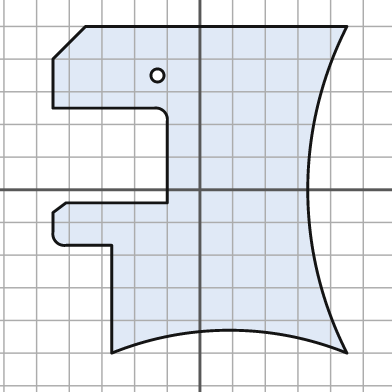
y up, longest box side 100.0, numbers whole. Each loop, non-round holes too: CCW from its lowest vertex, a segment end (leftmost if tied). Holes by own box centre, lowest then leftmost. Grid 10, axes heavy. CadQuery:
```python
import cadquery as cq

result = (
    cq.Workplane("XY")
    .moveTo(-27.0, -50.0)
    .threePointArc((9.0, -43.0), (45.0, -50.0))
    .threePointArc((33.0, 0.0), (45.0, 50.0))
    .lineTo(-35.0, 50.0)
    .lineTo(-45.0, 40.0)
    .lineTo(-45.0, 25.0)
    .lineTo(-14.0, 25.0)
    .threePointArc((-11.0, 24.0), (-10.0, 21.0))
    .lineTo(-10.0, -4.0)
    .lineTo(-41.0, -4.0)
    .lineTo(-45.0, -7.0)
    .lineTo(-45.0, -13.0)
    .threePointArc((-44.0, -16.0), (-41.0, -17.0))
    .lineTo(-27.0, -17.0)
    .close()
    .moveTo(-13.0, 35.0)
    .circle(2.0)
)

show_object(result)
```